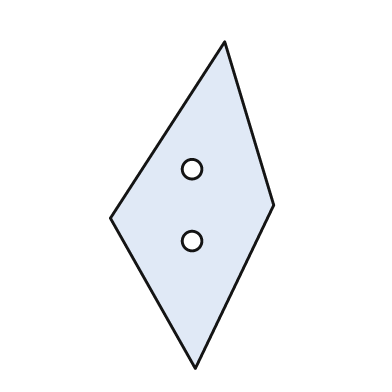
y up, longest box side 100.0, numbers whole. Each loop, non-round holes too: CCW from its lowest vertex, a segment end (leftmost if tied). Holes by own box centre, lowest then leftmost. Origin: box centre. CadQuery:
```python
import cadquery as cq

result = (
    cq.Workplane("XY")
    .moveTo(1.0, -50.0)
    .lineTo(25.0, 0.0)
    .lineTo(10.0, 50.0)
    .lineTo(-25.0, -4.0)
    .close()
    .moveTo(0.0, -11.0)
    .circle(3.0)
    .moveTo(0.0, 11.0)
    .circle(3.0)
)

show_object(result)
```